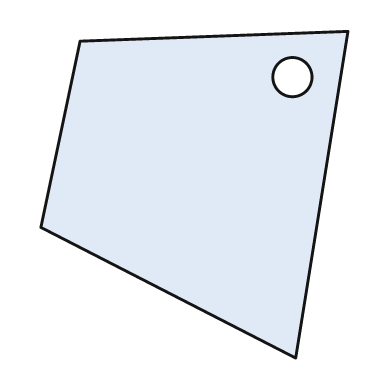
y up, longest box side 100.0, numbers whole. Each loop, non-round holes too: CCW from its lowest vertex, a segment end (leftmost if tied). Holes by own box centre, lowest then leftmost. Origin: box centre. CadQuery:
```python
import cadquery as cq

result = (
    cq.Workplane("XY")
    .moveTo(31.0, -50.0)
    .lineTo(47.0, 50.0)
    .lineTo(-35.0, 47.0)
    .lineTo(-47.0, -10.0)
    .close()
    .moveTo(30.0, 36.0)
    .circle(6.0)
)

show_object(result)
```